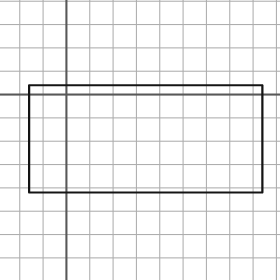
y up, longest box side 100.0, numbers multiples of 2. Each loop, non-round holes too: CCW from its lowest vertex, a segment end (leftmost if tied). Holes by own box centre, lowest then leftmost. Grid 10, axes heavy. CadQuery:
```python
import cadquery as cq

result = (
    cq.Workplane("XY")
    .moveTo(-16.0, -42.0)
    .lineTo(84.0, -42.0)
    .lineTo(84.0, 4.0)
    .lineTo(-16.0, 4.0)
    .close()
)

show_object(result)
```